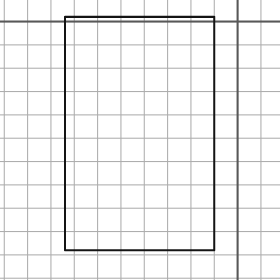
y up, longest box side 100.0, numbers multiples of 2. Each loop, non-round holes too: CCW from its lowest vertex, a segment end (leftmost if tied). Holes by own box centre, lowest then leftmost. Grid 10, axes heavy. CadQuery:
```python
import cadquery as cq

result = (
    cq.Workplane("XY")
    .moveTo(-74.0, -98.0)
    .lineTo(-10.0, -98.0)
    .lineTo(-10.0, 2.0)
    .lineTo(-74.0, 2.0)
    .close()
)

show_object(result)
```